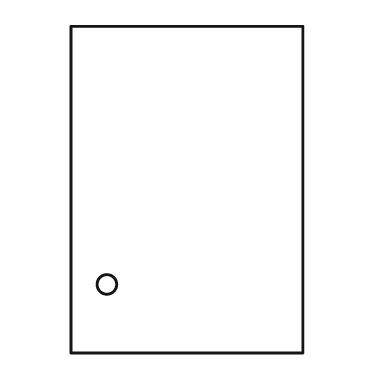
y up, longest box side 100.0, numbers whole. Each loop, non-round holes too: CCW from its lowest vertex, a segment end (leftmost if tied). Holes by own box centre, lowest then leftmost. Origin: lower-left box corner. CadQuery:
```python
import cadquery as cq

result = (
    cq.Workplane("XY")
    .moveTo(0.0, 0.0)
    .lineTo(71.0, 0.0)
    .lineTo(71.0, 100.0)
    .lineTo(0.0, 100.0)
    .close()
    .moveTo(11.0, 21.0)
    .circle(3.0)
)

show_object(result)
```